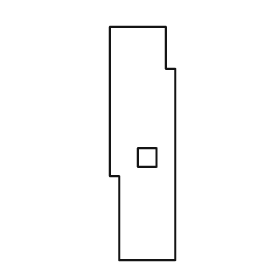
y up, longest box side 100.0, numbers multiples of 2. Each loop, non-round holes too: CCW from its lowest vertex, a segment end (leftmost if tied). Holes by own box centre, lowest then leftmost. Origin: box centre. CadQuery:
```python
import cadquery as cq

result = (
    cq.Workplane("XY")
    .moveTo(-10.0, -50.0)
    .lineTo(14.0, -50.0)
    .lineTo(14.0, 32.0)
    .lineTo(10.0, 32.0)
    .lineTo(10.0, 50.0)
    .lineTo(-14.0, 50.0)
    .lineTo(-14.0, -14.0)
    .lineTo(-10.0, -14.0)
    .close()
    .moveTo(-2.0, -10.0)
    .lineTo(6.0, -10.0)
    .lineTo(6.0, -2.0)
    .lineTo(-2.0, -2.0)
    .close()
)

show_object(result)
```